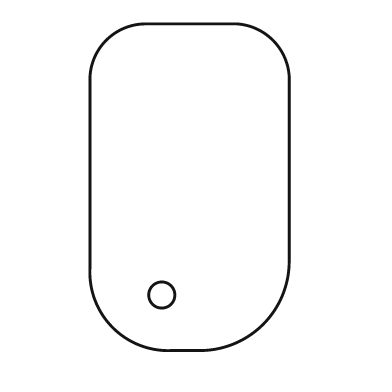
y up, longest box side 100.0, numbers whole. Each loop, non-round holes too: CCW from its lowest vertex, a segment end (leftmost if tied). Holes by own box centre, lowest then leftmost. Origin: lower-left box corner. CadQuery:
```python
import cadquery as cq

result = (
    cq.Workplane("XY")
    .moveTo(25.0, 0.0)
    .lineTo(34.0, 0.0)
    .threePointArc((53.0, 8.0), (61.0, 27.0))
    .lineTo(61.0, 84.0)
    .threePointArc((56.0, 95.0), (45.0, 100.0))
    .lineTo(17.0, 100.0)
    .threePointArc((5.0, 95.0), (0.0, 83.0))
    .lineTo(0.0, 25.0)
    .threePointArc((7.0, 7.0), (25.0, 0.0))
    .close()
    .moveTo(22.0, 17.0)
    .circle(4.0)
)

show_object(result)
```